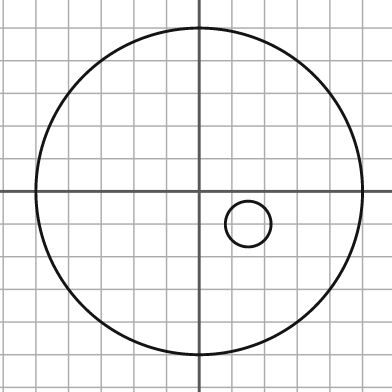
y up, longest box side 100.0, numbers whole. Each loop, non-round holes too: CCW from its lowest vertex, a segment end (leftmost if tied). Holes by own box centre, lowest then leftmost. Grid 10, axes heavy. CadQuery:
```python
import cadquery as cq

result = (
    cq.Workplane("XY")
    .moveTo(0.0, 0.0)
    .circle(50.0)
    .moveTo(15.0, -10.0)
    .circle(7.0)
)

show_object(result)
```